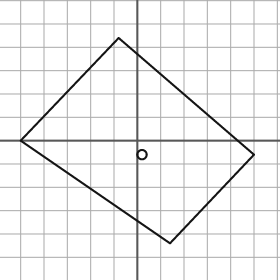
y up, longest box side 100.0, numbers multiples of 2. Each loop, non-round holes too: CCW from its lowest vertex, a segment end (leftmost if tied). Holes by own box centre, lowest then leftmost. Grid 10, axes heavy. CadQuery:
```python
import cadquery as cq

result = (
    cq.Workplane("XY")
    .moveTo(14.0, -44.0)
    .lineTo(50.0, -6.0)
    .lineTo(-8.0, 44.0)
    .lineTo(-50.0, 0.0)
    .close()
    .moveTo(2.0, -6.0)
    .circle(2.0)
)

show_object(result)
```